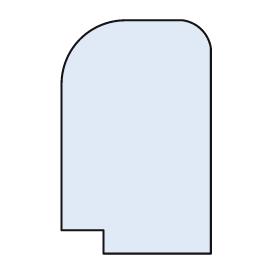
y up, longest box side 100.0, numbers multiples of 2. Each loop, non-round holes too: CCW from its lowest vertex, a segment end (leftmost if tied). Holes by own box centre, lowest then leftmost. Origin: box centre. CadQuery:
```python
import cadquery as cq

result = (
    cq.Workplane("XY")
    .moveTo(-14.0, -50.0)
    .lineTo(32.0, -50.0)
    .lineTo(32.0, 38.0)
    .threePointArc((28.0, 46.0), (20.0, 50.0))
    .lineTo(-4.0, 50.0)
    .threePointArc((-24.0, 42.0), (-32.0, 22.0))
    .lineTo(-32.0, -40.0)
    .lineTo(-14.0, -40.0)
    .close()
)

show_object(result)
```